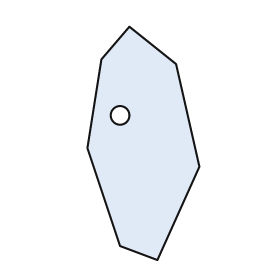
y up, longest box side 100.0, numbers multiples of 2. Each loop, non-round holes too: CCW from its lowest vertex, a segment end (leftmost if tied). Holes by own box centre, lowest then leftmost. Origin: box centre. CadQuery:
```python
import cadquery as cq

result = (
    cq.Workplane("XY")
    .moveTo(6.0, -50.0)
    .lineTo(24.0, -10.0)
    .lineTo(14.0, 34.0)
    .lineTo(-6.0, 50.0)
    .lineTo(-18.0, 36.0)
    .lineTo(-24.0, -2.0)
    .lineTo(-10.0, -44.0)
    .close()
    .moveTo(-10.0, 12.0)
    .circle(4.0)
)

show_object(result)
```